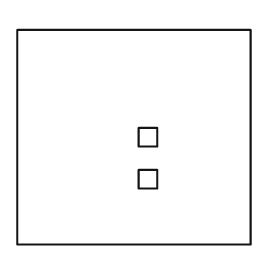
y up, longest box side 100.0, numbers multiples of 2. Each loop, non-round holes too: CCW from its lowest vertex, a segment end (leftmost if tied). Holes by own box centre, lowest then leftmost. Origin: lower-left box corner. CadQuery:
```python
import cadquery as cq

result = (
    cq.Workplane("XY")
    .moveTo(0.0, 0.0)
    .lineTo(100.0, 0.0)
    .lineTo(100.0, 92.0)
    .lineTo(0.0, 92.0)
    .close()
    .moveTo(52.0, 24.0)
    .lineTo(60.0, 24.0)
    .lineTo(60.0, 32.0)
    .lineTo(52.0, 32.0)
    .close()
    .moveTo(52.0, 42.0)
    .lineTo(60.0, 42.0)
    .lineTo(60.0, 50.0)
    .lineTo(52.0, 50.0)
    .close()
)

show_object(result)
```